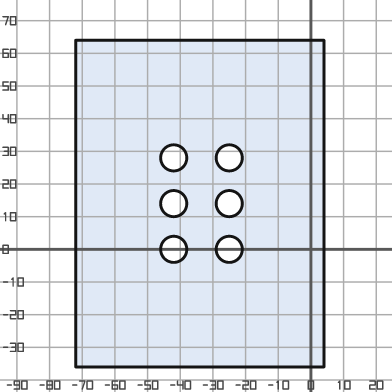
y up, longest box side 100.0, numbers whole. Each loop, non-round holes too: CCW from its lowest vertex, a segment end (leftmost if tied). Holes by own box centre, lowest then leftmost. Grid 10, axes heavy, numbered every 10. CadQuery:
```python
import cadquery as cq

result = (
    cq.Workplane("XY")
    .moveTo(-72.0, -36.0)
    .lineTo(4.0, -36.0)
    .lineTo(4.0, 64.0)
    .lineTo(-72.0, 64.0)
    .close()
    .moveTo(-42.0, 0.0)
    .circle(4.0)
    .moveTo(-25.0, 0.0)
    .circle(4.0)
    .moveTo(-42.0, 14.0)
    .circle(4.0)
    .moveTo(-25.0, 14.0)
    .circle(4.0)
    .moveTo(-42.0, 28.0)
    .circle(4.0)
    .moveTo(-25.0, 28.0)
    .circle(4.0)
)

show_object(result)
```